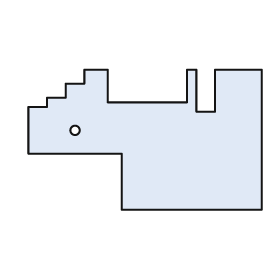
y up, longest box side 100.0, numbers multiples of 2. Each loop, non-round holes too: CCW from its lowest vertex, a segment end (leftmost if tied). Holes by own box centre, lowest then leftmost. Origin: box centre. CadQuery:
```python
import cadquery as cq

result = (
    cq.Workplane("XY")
    .moveTo(-10.0, -30.0)
    .lineTo(50.0, -30.0)
    .lineTo(50.0, 30.0)
    .lineTo(30.0, 30.0)
    .lineTo(30.0, 12.0)
    .lineTo(22.0, 12.0)
    .lineTo(22.0, 30.0)
    .lineTo(18.0, 30.0)
    .lineTo(18.0, 16.0)
    .lineTo(-16.0, 16.0)
    .lineTo(-16.0, 30.0)
    .lineTo(-26.0, 30.0)
    .lineTo(-26.0, 24.0)
    .lineTo(-34.0, 24.0)
    .lineTo(-34.0, 18.0)
    .lineTo(-42.0, 18.0)
    .lineTo(-42.0, 14.0)
    .lineTo(-50.0, 14.0)
    .lineTo(-50.0, -6.0)
    .lineTo(-10.0, -6.0)
    .close()
    .moveTo(-30.0, 4.0)
    .circle(2.0)
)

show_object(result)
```